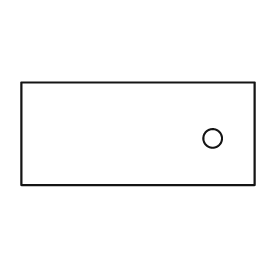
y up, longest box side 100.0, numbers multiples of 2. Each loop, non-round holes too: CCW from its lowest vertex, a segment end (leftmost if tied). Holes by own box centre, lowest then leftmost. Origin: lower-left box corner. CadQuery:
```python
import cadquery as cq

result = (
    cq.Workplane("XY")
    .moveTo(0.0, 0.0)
    .lineTo(100.0, 0.0)
    .lineTo(100.0, 44.0)
    .lineTo(0.0, 44.0)
    .close()
    .moveTo(82.0, 20.0)
    .circle(4.0)
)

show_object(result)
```